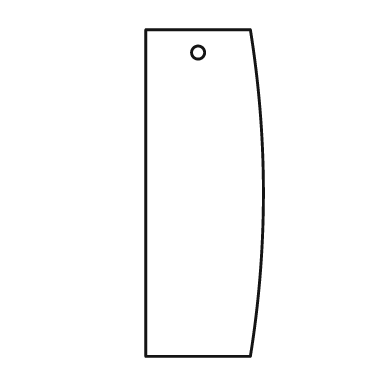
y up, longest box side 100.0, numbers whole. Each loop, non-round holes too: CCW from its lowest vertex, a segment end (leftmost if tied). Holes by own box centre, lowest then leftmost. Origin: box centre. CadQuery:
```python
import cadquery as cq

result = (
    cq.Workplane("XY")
    .moveTo(-18.0, -50.0)
    .lineTo(14.0, -50.0)
    .threePointArc((18.0, 0.0), (14.0, 50.0))
    .lineTo(-18.0, 50.0)
    .close()
    .moveTo(-2.0, 43.0)
    .circle(2.0)
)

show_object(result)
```